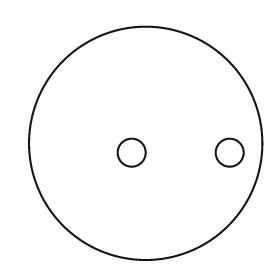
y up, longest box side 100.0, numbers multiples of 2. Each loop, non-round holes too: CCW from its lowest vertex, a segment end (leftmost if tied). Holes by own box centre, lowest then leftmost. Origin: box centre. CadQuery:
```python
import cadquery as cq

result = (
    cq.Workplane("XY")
    .moveTo(0.0, 0.0)
    .circle(50.0)
    .moveTo(-6.0, -4.0)
    .circle(6.0)
    .moveTo(36.0, -4.0)
    .circle(6.0)
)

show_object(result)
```